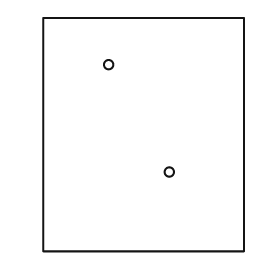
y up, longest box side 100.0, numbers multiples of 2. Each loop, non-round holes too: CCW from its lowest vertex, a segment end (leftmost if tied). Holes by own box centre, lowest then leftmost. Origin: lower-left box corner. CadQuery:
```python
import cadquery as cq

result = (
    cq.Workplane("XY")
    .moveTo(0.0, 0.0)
    .lineTo(86.0, 0.0)
    .lineTo(86.0, 100.0)
    .lineTo(0.0, 100.0)
    .close()
    .moveTo(54.0, 34.0)
    .circle(2.0)
    .moveTo(28.0, 80.0)
    .circle(2.0)
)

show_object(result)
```